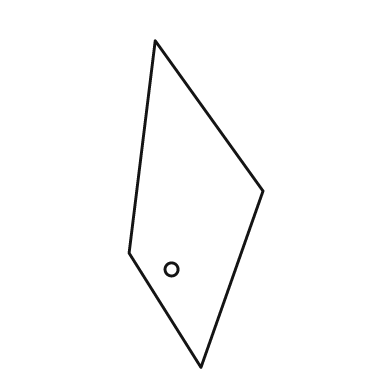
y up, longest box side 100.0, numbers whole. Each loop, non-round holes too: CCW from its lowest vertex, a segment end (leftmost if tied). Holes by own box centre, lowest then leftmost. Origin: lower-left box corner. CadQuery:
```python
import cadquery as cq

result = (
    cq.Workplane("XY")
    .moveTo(22.0, 0.0)
    .lineTo(41.0, 54.0)
    .lineTo(8.0, 100.0)
    .lineTo(0.0, 35.0)
    .close()
    .moveTo(13.0, 30.0)
    .circle(2.0)
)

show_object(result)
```